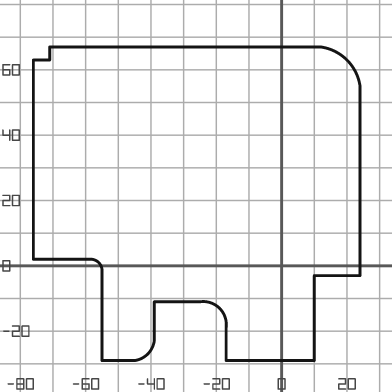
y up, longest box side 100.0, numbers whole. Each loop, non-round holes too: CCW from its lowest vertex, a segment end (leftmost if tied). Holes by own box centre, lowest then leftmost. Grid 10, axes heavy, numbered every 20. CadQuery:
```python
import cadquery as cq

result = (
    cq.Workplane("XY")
    .moveTo(-55.0, -29.0)
    .lineTo(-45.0, -29.0)
    .threePointArc((-41.0, -27.0), (-39.0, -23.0))
    .lineTo(-39.0, -11.0)
    .lineTo(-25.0, -11.0)
    .threePointArc((-19.0, -13.0), (-17.0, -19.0))
    .lineTo(-17.0, -29.0)
    .lineTo(10.0, -29.0)
    .lineTo(10.0, -3.0)
    .lineTo(24.0, -3.0)
    .lineTo(24.0, 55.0)
    .threePointArc((20.0, 63.0), (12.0, 67.0))
    .lineTo(-71.0, 67.0)
    .lineTo(-71.0, 63.0)
    .lineTo(-76.0, 63.0)
    .lineTo(-76.0, 2.0)
    .lineTo(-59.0, 2.0)
    .threePointArc((-56.0, 1.0), (-55.0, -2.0))
    .close()
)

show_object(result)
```